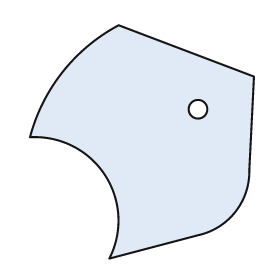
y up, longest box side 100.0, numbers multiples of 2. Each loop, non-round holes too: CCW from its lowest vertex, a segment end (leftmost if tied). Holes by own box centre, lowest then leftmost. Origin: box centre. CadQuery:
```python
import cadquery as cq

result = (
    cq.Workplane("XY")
    .moveTo(-14.0, -50.0)
    .lineTo(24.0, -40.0)
    .threePointArc((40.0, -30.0), (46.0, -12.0))
    .lineTo(48.0, 28.0)
    .lineTo(-10.0, 50.0)
    .threePointArc((-34.0, 30.0), (-48.0, 2.0))
    .threePointArc((-16.0, -14.0), (-14.0, -50.0))
    .close()
    .moveTo(24.0, 14.0)
    .circle(4.0)
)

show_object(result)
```